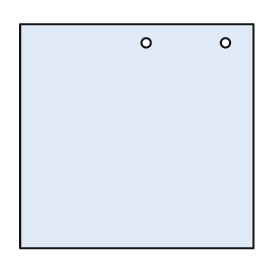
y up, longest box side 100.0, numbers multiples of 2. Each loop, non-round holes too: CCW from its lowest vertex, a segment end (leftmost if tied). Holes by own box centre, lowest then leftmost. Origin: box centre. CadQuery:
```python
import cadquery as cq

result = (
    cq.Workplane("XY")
    .moveTo(-50.0, -48.0)
    .lineTo(50.0, -48.0)
    .lineTo(50.0, 48.0)
    .lineTo(-50.0, 48.0)
    .close()
    .moveTo(4.0, 40.0)
    .circle(2.0)
    .moveTo(38.0, 40.0)
    .circle(2.0)
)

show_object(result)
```